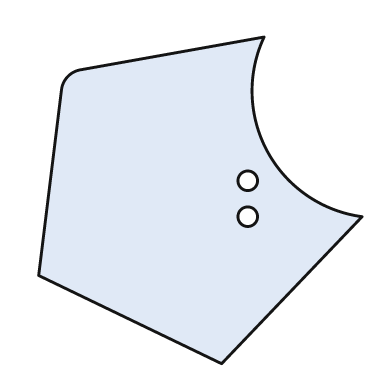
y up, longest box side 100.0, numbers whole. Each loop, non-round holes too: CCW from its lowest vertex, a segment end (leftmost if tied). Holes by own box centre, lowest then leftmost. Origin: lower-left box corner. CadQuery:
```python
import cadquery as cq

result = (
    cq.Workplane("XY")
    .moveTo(56.0, 0.0)
    .lineTo(99.0, 45.0)
    .threePointArc((70.0, 65.0), (69.0, 100.0))
    .lineTo(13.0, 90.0)
    .threePointArc((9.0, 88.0), (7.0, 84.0))
    .lineTo(0.0, 27.0)
    .close()
    .moveTo(64.0, 45.0)
    .circle(3.0)
    .moveTo(64.0, 56.0)
    .circle(3.0)
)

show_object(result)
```